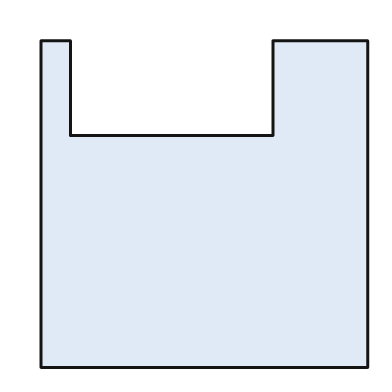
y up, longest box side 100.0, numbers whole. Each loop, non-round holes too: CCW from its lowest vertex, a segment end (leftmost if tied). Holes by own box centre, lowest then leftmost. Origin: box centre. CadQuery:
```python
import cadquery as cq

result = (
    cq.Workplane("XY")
    .moveTo(-50.0, -50.0)
    .lineTo(50.0, -50.0)
    .lineTo(50.0, 50.0)
    .lineTo(21.0, 50.0)
    .lineTo(21.0, 21.0)
    .lineTo(-41.0, 21.0)
    .lineTo(-41.0, 50.0)
    .lineTo(-50.0, 50.0)
    .close()
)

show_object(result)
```